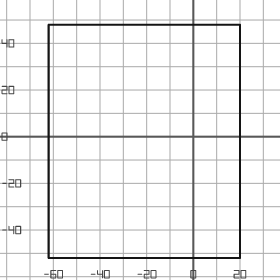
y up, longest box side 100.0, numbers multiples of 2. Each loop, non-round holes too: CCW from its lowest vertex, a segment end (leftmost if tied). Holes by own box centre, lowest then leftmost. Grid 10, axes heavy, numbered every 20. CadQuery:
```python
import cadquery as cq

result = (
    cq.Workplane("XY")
    .moveTo(-62.0, -52.0)
    .lineTo(20.0, -52.0)
    .lineTo(20.0, 48.0)
    .lineTo(-62.0, 48.0)
    .close()
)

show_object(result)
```